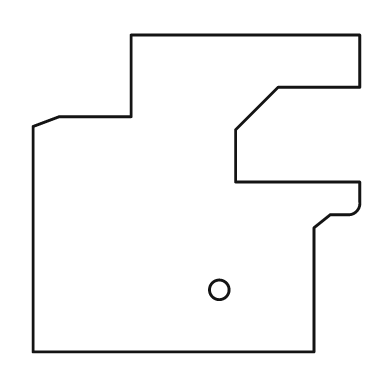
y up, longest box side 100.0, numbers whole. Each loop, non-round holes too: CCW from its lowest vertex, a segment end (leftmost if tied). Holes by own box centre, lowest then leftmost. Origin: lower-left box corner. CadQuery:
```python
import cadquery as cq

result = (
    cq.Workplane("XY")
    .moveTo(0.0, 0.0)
    .lineTo(86.0, 0.0)
    .lineTo(86.0, 38.0)
    .lineTo(91.0, 42.0)
    .lineTo(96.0, 42.0)
    .threePointArc((99.0, 43.0), (100.0, 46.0))
    .lineTo(100.0, 52.0)
    .lineTo(62.0, 52.0)
    .lineTo(62.0, 68.0)
    .lineTo(75.0, 81.0)
    .lineTo(100.0, 81.0)
    .lineTo(100.0, 97.0)
    .lineTo(30.0, 97.0)
    .lineTo(30.0, 72.0)
    .lineTo(8.0, 72.0)
    .lineTo(0.0, 69.0)
    .close()
    .moveTo(57.0, 19.0)
    .circle(3.0)
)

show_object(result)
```